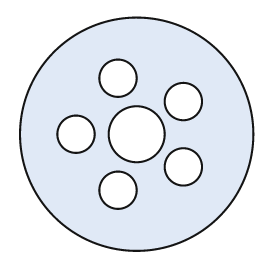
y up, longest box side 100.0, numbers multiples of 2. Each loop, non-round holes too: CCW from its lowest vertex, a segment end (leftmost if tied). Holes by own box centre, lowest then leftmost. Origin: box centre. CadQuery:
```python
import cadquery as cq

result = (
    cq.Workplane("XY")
    .moveTo(0.0, 0.0)
    .circle(50.0)
    .moveTo(-8.0, -24.0)
    .circle(8.0)
    .moveTo(20.0, -14.0)
    .circle(8.0)
    .moveTo(-26.0, 0.0)
    .circle(8.0)
    .moveTo(0.0, 0.0)
    .circle(12.0)
    .moveTo(20.0, 14.0)
    .circle(8.0)
    .moveTo(-8.0, 24.0)
    .circle(8.0)
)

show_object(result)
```